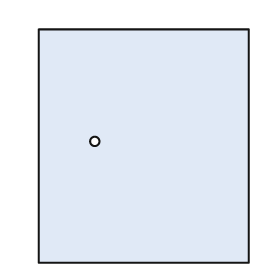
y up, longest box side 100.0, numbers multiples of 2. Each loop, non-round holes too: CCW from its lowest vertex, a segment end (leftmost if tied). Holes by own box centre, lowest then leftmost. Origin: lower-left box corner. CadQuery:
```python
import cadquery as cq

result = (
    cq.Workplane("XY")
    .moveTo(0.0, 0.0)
    .lineTo(90.0, 0.0)
    .lineTo(90.0, 100.0)
    .lineTo(0.0, 100.0)
    .close()
    .moveTo(24.0, 52.0)
    .circle(2.0)
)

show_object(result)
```